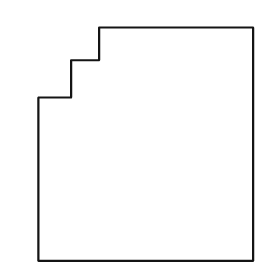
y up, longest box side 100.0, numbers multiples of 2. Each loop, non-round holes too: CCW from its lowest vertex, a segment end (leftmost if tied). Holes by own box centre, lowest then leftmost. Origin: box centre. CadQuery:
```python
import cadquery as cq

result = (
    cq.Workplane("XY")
    .moveTo(-46.0, -50.0)
    .lineTo(46.0, -50.0)
    .lineTo(46.0, 50.0)
    .lineTo(-20.0, 50.0)
    .lineTo(-20.0, 36.0)
    .lineTo(-32.0, 36.0)
    .lineTo(-32.0, 20.0)
    .lineTo(-46.0, 20.0)
    .close()
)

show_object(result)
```